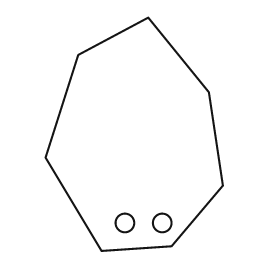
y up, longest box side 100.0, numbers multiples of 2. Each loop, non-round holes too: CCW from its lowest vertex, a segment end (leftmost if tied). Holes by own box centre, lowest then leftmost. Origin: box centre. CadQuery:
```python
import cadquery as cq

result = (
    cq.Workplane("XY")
    .moveTo(-14.0, -50.0)
    .lineTo(16.0, -48.0)
    .lineTo(38.0, -22.0)
    .lineTo(32.0, 18.0)
    .lineTo(6.0, 50.0)
    .lineTo(-24.0, 34.0)
    .lineTo(-38.0, -10.0)
    .close()
    .moveTo(-4.0, -38.0)
    .circle(4.0)
    .moveTo(12.0, -38.0)
    .circle(4.0)
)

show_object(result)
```